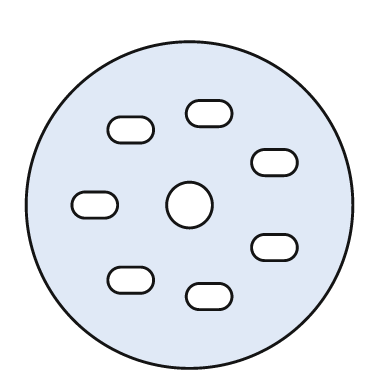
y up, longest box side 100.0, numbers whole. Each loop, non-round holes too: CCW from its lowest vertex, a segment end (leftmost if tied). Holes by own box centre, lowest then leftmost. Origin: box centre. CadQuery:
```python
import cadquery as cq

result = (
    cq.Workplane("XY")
    .moveTo(0.0, 0.0)
    .circle(50.0)
    .moveTo(3.0, -32.0)
    .lineTo(9.0, -32.0)
    .threePointArc((13.0, -28.0), (9.0, -24.0))
    .lineTo(3.0, -24.0)
    .threePointArc((-1.0, -28.0), (3.0, -32.0))
    .close()
    .moveTo(-21.0, -27.0)
    .lineTo(-15.0, -27.0)
    .threePointArc((-11.0, -23.0), (-15.0, -19.0))
    .lineTo(-21.0, -19.0)
    .threePointArc((-25.0, -23.0), (-21.0, -27.0))
    .close()
    .moveTo(23.0, -17.0)
    .lineTo(29.0, -17.0)
    .threePointArc((33.0, -13.0), (29.0, -9.0))
    .lineTo(23.0, -9.0)
    .threePointArc((19.0, -13.0), (23.0, -17.0))
    .close()
    .moveTo(-32.0, -4.0)
    .lineTo(-26.0, -4.0)
    .threePointArc((-22.0, 0.0), (-26.0, 4.0))
    .lineTo(-32.0, 4.0)
    .threePointArc((-36.0, 0.0), (-32.0, -4.0))
    .close()
    .moveTo(0.0, 0.0)
    .circle(7.0)
    .moveTo(23.0, 9.0)
    .lineTo(29.0, 9.0)
    .threePointArc((33.0, 13.0), (29.0, 17.0))
    .lineTo(23.0, 17.0)
    .threePointArc((19.0, 13.0), (23.0, 9.0))
    .close()
    .moveTo(-21.0, 19.0)
    .lineTo(-15.0, 19.0)
    .threePointArc((-11.0, 23.0), (-15.0, 27.0))
    .lineTo(-21.0, 27.0)
    .threePointArc((-25.0, 23.0), (-21.0, 19.0))
    .close()
    .moveTo(3.0, 24.0)
    .lineTo(9.0, 24.0)
    .threePointArc((13.0, 28.0), (9.0, 32.0))
    .lineTo(3.0, 32.0)
    .threePointArc((-1.0, 28.0), (3.0, 24.0))
    .close()
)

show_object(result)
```